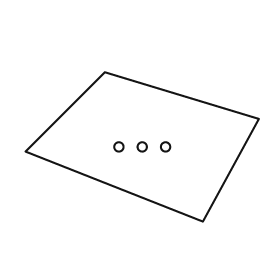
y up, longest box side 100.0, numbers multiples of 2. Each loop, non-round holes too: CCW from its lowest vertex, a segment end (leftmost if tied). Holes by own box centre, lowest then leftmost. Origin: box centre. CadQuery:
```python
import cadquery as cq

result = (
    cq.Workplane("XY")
    .moveTo(26.0, -32.0)
    .lineTo(50.0, 12.0)
    .lineTo(-16.0, 32.0)
    .lineTo(-50.0, -2.0)
    .close()
    .moveTo(-10.0, 0.0)
    .circle(2.0)
    .moveTo(0.0, 0.0)
    .circle(2.0)
    .moveTo(10.0, 0.0)
    .circle(2.0)
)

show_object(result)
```